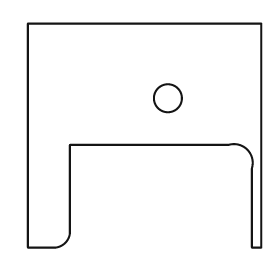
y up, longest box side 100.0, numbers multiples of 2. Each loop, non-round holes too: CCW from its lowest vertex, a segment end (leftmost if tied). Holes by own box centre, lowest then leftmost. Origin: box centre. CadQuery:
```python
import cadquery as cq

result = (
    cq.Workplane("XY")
    .moveTo(-50.0, -48.0)
    .lineTo(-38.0, -48.0)
    .threePointArc((-34.0, -46.0), (-32.0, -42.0))
    .lineTo(-32.0, -4.0)
    .lineTo(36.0, -4.0)
    .threePointArc((44.0, -6.0), (46.0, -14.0))
    .lineTo(46.0, -48.0)
    .lineTo(50.0, -48.0)
    .lineTo(50.0, 48.0)
    .lineTo(-50.0, 48.0)
    .close()
    .moveTo(10.0, 16.0)
    .circle(6.0)
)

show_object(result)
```